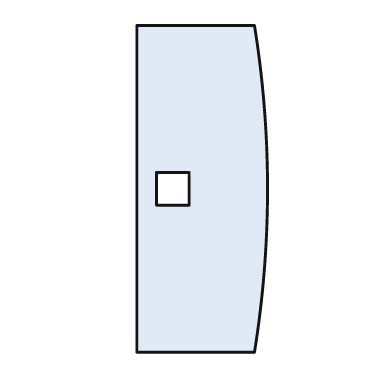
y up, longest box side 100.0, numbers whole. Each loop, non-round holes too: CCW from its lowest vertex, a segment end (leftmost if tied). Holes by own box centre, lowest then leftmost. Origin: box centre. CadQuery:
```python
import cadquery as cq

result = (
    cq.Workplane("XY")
    .moveTo(-20.0, -50.0)
    .lineTo(16.0, -50.0)
    .threePointArc((20.0, 0.0), (16.0, 50.0))
    .lineTo(-20.0, 50.0)
    .close()
    .moveTo(-14.0, -5.0)
    .lineTo(-4.0, -5.0)
    .lineTo(-4.0, 5.0)
    .lineTo(-14.0, 5.0)
    .close()
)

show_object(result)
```